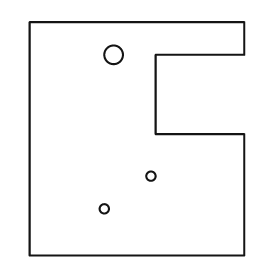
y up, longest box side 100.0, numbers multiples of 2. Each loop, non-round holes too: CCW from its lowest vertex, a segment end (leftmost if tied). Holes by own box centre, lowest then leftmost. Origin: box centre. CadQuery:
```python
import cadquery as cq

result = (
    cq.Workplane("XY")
    .moveTo(-46.0, -50.0)
    .lineTo(46.0, -50.0)
    .lineTo(46.0, 2.0)
    .lineTo(8.0, 2.0)
    .lineTo(8.0, 36.0)
    .lineTo(46.0, 36.0)
    .lineTo(46.0, 50.0)
    .lineTo(-46.0, 50.0)
    .close()
    .moveTo(-14.0, -30.0)
    .circle(2.0)
    .moveTo(6.0, -16.0)
    .circle(2.0)
    .moveTo(-10.0, 36.0)
    .circle(4.0)
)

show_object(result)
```